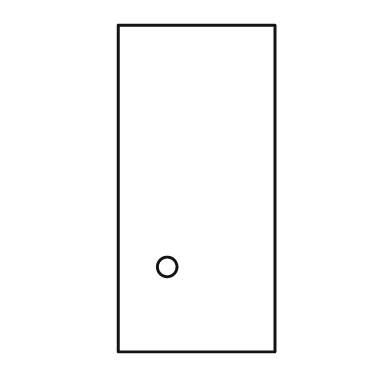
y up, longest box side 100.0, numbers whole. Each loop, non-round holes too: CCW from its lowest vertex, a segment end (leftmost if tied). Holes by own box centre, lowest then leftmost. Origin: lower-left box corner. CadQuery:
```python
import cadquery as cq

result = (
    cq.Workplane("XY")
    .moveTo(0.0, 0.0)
    .lineTo(48.0, 0.0)
    .lineTo(48.0, 100.0)
    .lineTo(0.0, 100.0)
    .close()
    .moveTo(15.0, 26.0)
    .circle(3.0)
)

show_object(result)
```